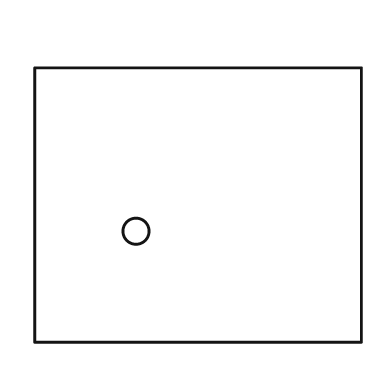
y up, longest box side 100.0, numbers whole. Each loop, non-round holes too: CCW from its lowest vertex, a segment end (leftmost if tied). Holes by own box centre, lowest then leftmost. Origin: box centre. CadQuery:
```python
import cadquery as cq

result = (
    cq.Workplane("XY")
    .moveTo(-50.0, -42.0)
    .lineTo(50.0, -42.0)
    .lineTo(50.0, 42.0)
    .lineTo(-50.0, 42.0)
    .close()
    .moveTo(-19.0, -8.0)
    .circle(4.0)
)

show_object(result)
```